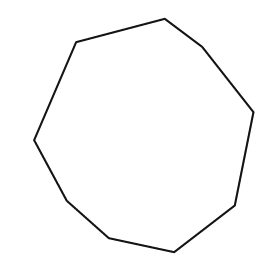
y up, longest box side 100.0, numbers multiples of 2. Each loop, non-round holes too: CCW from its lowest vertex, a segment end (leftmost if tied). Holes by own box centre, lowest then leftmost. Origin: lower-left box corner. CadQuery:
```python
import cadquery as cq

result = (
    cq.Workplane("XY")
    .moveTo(60.0, 0.0)
    .lineTo(86.0, 20.0)
    .lineTo(94.0, 60.0)
    .lineTo(72.0, 88.0)
    .lineTo(56.0, 100.0)
    .lineTo(18.0, 90.0)
    .lineTo(0.0, 48.0)
    .lineTo(14.0, 22.0)
    .lineTo(32.0, 6.0)
    .close()
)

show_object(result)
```